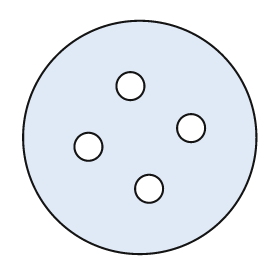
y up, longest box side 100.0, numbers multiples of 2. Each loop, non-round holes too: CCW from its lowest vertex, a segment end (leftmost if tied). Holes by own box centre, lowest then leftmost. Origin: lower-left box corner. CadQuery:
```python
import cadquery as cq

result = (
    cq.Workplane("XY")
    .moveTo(50.0, 50.0)
    .circle(50.0)
    .moveTo(54.0, 28.0)
    .circle(6.0)
    .moveTo(28.0, 46.0)
    .circle(6.0)
    .moveTo(72.0, 54.0)
    .circle(6.0)
    .moveTo(46.0, 72.0)
    .circle(6.0)
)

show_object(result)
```